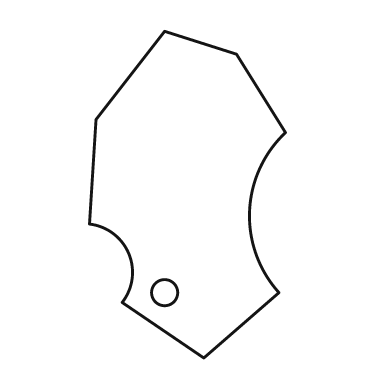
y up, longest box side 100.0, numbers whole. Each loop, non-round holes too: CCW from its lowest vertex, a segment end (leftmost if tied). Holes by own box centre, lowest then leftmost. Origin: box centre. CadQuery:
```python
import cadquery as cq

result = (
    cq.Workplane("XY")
    .moveTo(5.0, -50.0)
    .lineTo(28.0, -30.0)
    .threePointArc((19.0, -5.0), (30.0, 19.0))
    .lineTo(15.0, 43.0)
    .lineTo(-7.0, 50.0)
    .lineTo(-28.0, 23.0)
    .lineTo(-30.0, -9.0)
    .threePointArc((-18.0, -18.0), (-20.0, -33.0))
    .close()
    .moveTo(-7.0, -30.0)
    .circle(4.0)
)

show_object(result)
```